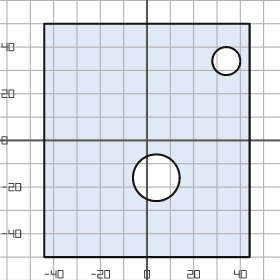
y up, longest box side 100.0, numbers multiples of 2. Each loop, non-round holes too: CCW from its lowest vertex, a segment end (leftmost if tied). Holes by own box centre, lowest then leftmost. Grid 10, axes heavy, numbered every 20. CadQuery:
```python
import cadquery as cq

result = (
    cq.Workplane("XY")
    .moveTo(-44.0, -50.0)
    .lineTo(44.0, -50.0)
    .lineTo(44.0, 50.0)
    .lineTo(-44.0, 50.0)
    .close()
    .moveTo(4.0, -16.0)
    .circle(10.0)
    .moveTo(34.0, 34.0)
    .circle(6.0)
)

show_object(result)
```